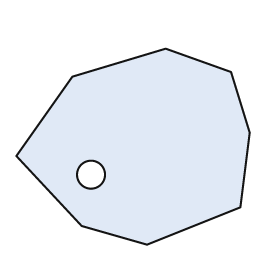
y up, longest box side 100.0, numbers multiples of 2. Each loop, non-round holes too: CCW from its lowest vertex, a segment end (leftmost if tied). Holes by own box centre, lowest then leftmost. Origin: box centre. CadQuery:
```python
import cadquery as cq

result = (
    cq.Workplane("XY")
    .moveTo(6.0, -42.0)
    .lineTo(46.0, -26.0)
    .lineTo(50.0, 6.0)
    .lineTo(42.0, 32.0)
    .lineTo(14.0, 42.0)
    .lineTo(-26.0, 30.0)
    .lineTo(-50.0, -4.0)
    .lineTo(-22.0, -34.0)
    .close()
    .moveTo(-18.0, -12.0)
    .circle(6.0)
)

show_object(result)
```